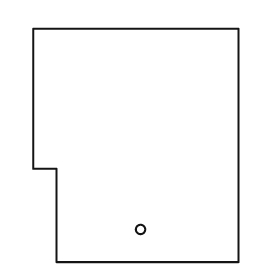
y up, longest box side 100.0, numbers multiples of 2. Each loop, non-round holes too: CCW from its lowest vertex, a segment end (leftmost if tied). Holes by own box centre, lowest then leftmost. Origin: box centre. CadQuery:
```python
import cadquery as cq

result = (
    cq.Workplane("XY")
    .moveTo(-34.0, -50.0)
    .lineTo(44.0, -50.0)
    .lineTo(44.0, 50.0)
    .lineTo(-44.0, 50.0)
    .lineTo(-44.0, -10.0)
    .lineTo(-34.0, -10.0)
    .close()
    .moveTo(2.0, -36.0)
    .circle(2.0)
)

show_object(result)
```